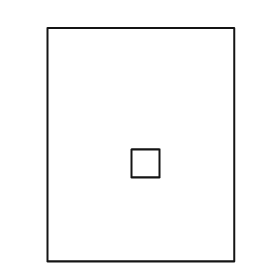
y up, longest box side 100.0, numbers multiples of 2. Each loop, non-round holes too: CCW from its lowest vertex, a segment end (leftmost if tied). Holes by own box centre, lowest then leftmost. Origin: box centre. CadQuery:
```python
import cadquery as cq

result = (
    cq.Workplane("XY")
    .moveTo(-40.0, -50.0)
    .lineTo(40.0, -50.0)
    .lineTo(40.0, 50.0)
    .lineTo(-40.0, 50.0)
    .close()
    .moveTo(-4.0, -14.0)
    .lineTo(8.0, -14.0)
    .lineTo(8.0, -2.0)
    .lineTo(-4.0, -2.0)
    .close()
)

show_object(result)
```